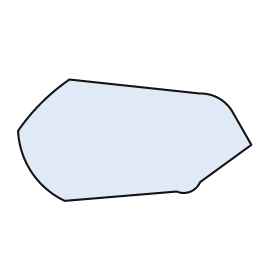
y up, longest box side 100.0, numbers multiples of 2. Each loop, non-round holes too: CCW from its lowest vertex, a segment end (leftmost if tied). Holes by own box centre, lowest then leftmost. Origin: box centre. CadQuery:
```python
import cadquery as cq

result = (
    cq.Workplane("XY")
    .moveTo(-30.0, -26.0)
    .lineTo(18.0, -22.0)
    .threePointArc((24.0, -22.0), (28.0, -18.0))
    .lineTo(50.0, -2.0)
    .lineTo(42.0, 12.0)
    .threePointArc((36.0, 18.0), (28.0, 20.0))
    .lineTo(-28.0, 26.0)
    .threePointArc((-40.0, 16.0), (-50.0, 4.0))
    .threePointArc((-44.0, -14.0), (-30.0, -26.0))
    .close()
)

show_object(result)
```